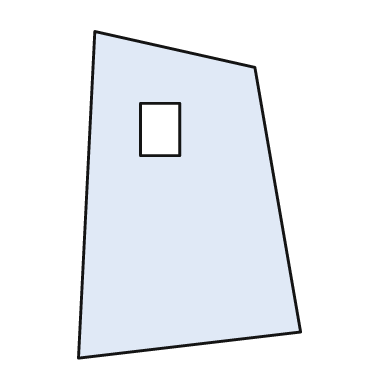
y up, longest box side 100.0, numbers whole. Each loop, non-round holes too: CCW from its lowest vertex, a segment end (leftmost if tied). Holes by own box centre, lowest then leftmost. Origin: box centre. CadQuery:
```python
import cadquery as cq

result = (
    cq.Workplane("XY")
    .moveTo(-34.0, -50.0)
    .lineTo(34.0, -42.0)
    .lineTo(20.0, 39.0)
    .lineTo(-29.0, 50.0)
    .close()
    .moveTo(-15.0, 12.0)
    .lineTo(-3.0, 12.0)
    .lineTo(-3.0, 28.0)
    .lineTo(-15.0, 28.0)
    .close()
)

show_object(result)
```